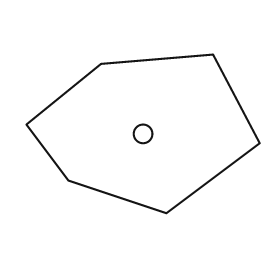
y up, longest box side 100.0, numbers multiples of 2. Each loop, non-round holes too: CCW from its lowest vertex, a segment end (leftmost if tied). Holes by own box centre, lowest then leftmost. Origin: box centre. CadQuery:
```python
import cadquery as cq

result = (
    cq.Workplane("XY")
    .moveTo(10.0, -34.0)
    .lineTo(50.0, -4.0)
    .lineTo(30.0, 34.0)
    .lineTo(-18.0, 30.0)
    .lineTo(-50.0, 4.0)
    .lineTo(-32.0, -20.0)
    .close()
    .moveTo(0.0, 0.0)
    .circle(4.0)
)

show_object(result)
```